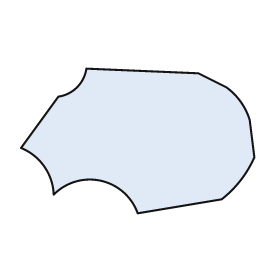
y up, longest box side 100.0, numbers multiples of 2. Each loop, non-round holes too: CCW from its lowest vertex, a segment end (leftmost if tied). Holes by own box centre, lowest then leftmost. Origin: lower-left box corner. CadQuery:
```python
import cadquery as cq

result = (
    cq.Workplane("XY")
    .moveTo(50.0, 0.0)
    .lineTo(86.0, 6.0)
    .threePointArc((94.0, 14.0), (100.0, 24.0))
    .lineTo(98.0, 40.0)
    .threePointArc((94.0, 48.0), (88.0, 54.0))
    .lineTo(76.0, 60.0)
    .lineTo(28.0, 62.0)
    .threePointArc((24.0, 54.0), (16.0, 50.0))
    .lineTo(0.0, 28.0)
    .threePointArc((10.0, 20.0), (14.0, 8.0))
    .threePointArc((34.0, 14.0), (50.0, 0.0))
    .close()
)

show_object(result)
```